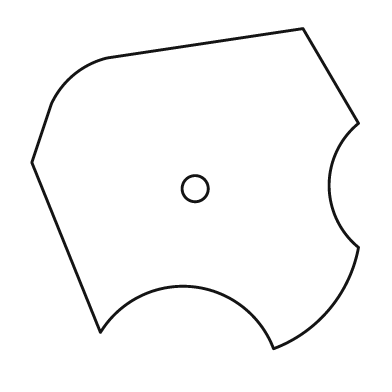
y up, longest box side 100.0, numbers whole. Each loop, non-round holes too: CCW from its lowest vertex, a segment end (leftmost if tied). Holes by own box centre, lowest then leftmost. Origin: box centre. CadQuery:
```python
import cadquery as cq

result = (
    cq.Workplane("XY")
    .moveTo(24.0, -49.0)
    .threePointArc((41.0, -37.0), (50.0, -18.0))
    .threePointArc((41.0, 1.0), (50.0, 20.0))
    .lineTo(33.0, 49.0)
    .lineTo(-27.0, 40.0)
    .threePointArc((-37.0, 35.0), (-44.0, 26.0))
    .lineTo(-50.0, 8.0)
    .lineTo(-29.0, -44.0)
    .threePointArc((-1.0, -30.0), (24.0, -49.0))
    .close()
    .moveTo(0.0, 0.0)
    .circle(4.0)
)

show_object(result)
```